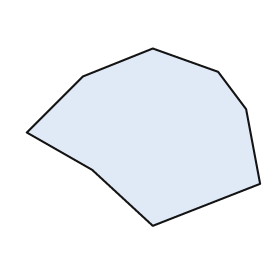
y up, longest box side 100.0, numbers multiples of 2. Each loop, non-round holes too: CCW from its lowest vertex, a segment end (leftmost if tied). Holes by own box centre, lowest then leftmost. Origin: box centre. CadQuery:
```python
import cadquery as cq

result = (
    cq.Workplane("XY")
    .moveTo(4.0, -38.0)
    .lineTo(50.0, -20.0)
    .lineTo(44.0, 12.0)
    .lineTo(32.0, 28.0)
    .lineTo(4.0, 38.0)
    .lineTo(-26.0, 26.0)
    .lineTo(-50.0, 2.0)
    .lineTo(-22.0, -14.0)
    .close()
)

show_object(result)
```